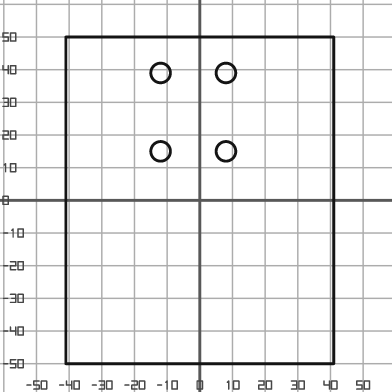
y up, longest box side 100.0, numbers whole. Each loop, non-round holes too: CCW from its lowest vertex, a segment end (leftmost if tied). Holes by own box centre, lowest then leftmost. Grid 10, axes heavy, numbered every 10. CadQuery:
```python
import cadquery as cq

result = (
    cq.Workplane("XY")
    .moveTo(-41.0, -50.0)
    .lineTo(41.0, -50.0)
    .lineTo(41.0, 50.0)
    .lineTo(-41.0, 50.0)
    .close()
    .moveTo(-12.0, 15.0)
    .circle(3.0)
    .moveTo(8.0, 15.0)
    .circle(3.0)
    .moveTo(-12.0, 39.0)
    .circle(3.0)
    .moveTo(8.0, 39.0)
    .circle(3.0)
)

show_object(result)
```